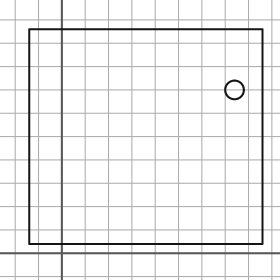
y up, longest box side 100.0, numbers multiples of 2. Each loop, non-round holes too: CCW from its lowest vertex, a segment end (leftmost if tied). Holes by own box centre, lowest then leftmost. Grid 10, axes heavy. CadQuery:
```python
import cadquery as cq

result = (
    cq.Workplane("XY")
    .moveTo(-14.0, 4.0)
    .lineTo(86.0, 4.0)
    .lineTo(86.0, 96.0)
    .lineTo(-14.0, 96.0)
    .close()
    .moveTo(74.0, 70.0)
    .circle(4.0)
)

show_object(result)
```